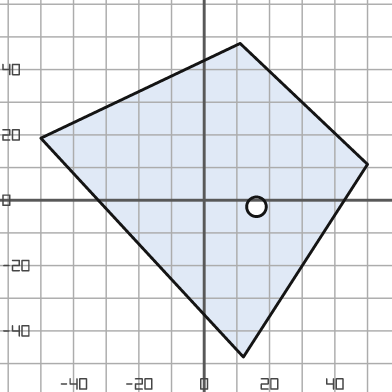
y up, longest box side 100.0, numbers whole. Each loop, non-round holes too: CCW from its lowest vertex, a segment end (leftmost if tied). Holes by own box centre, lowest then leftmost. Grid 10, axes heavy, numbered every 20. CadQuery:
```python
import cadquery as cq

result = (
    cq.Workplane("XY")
    .moveTo(12.0, -48.0)
    .lineTo(50.0, 11.0)
    .lineTo(11.0, 48.0)
    .lineTo(-50.0, 19.0)
    .close()
    .moveTo(16.0, -2.0)
    .circle(3.0)
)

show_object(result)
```